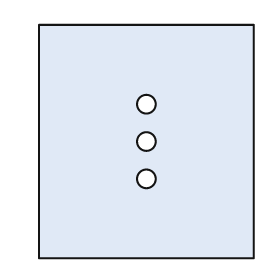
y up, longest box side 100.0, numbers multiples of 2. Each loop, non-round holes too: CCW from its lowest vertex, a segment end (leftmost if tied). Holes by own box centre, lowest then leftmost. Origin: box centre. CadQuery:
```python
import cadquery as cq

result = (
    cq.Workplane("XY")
    .moveTo(-46.0, -50.0)
    .lineTo(46.0, -50.0)
    .lineTo(46.0, 50.0)
    .lineTo(-46.0, 50.0)
    .close()
    .moveTo(0.0, -16.0)
    .circle(4.0)
    .moveTo(0.0, 0.0)
    .circle(4.0)
    .moveTo(0.0, 16.0)
    .circle(4.0)
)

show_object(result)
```